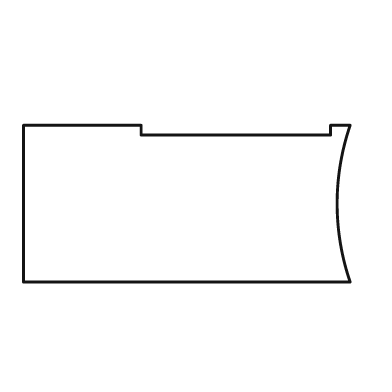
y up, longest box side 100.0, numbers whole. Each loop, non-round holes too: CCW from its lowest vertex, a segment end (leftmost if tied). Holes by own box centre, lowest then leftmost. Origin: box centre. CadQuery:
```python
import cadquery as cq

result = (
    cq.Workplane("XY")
    .moveTo(-50.0, -24.0)
    .lineTo(50.0, -24.0)
    .threePointArc((46.0, 0.0), (50.0, 24.0))
    .lineTo(44.0, 24.0)
    .lineTo(44.0, 21.0)
    .lineTo(-14.0, 21.0)
    .lineTo(-14.0, 24.0)
    .lineTo(-50.0, 24.0)
    .close()
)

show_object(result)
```